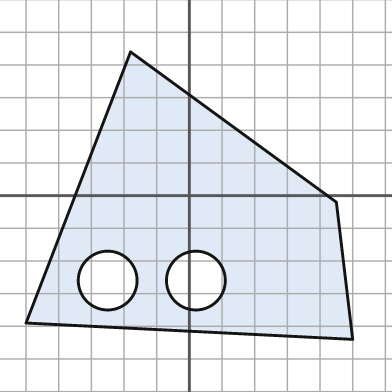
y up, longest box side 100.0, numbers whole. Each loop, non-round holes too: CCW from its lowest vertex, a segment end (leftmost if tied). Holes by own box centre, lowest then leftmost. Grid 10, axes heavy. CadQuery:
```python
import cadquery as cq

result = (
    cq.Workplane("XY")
    .moveTo(50.0, -44.0)
    .lineTo(45.0, -2.0)
    .lineTo(-18.0, 44.0)
    .lineTo(-50.0, -39.0)
    .close()
    .moveTo(-25.0, -26.0)
    .circle(9.0)
    .moveTo(2.0, -26.0)
    .circle(9.0)
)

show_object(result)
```